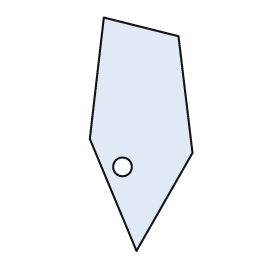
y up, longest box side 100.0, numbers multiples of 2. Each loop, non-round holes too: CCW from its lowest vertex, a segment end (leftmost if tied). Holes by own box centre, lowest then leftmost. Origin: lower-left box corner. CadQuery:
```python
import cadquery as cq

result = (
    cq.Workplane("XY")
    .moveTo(20.0, 0.0)
    .lineTo(44.0, 42.0)
    .lineTo(38.0, 92.0)
    .lineTo(6.0, 100.0)
    .lineTo(0.0, 48.0)
    .close()
    .moveTo(14.0, 36.0)
    .circle(4.0)
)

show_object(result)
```